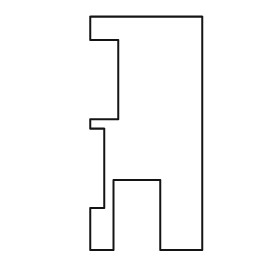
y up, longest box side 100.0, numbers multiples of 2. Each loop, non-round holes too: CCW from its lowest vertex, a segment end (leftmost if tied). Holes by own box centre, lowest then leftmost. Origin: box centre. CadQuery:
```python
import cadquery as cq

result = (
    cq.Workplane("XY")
    .moveTo(-24.0, -50.0)
    .lineTo(-14.0, -50.0)
    .lineTo(-14.0, -20.0)
    .lineTo(6.0, -20.0)
    .lineTo(6.0, -50.0)
    .lineTo(24.0, -50.0)
    .lineTo(24.0, 50.0)
    .lineTo(-24.0, 50.0)
    .lineTo(-24.0, 40.0)
    .lineTo(-12.0, 40.0)
    .lineTo(-12.0, 6.0)
    .lineTo(-24.0, 6.0)
    .lineTo(-24.0, 2.0)
    .lineTo(-18.0, 2.0)
    .lineTo(-18.0, -32.0)
    .lineTo(-24.0, -32.0)
    .close()
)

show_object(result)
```